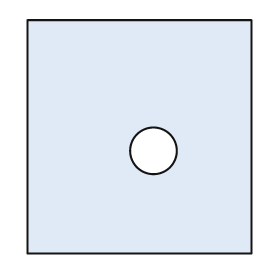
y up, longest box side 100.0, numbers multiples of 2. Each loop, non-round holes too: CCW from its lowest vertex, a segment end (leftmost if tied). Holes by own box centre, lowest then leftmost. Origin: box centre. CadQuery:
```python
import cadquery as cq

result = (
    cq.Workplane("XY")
    .moveTo(-48.0, -50.0)
    .lineTo(48.0, -50.0)
    .lineTo(48.0, 50.0)
    .lineTo(-48.0, 50.0)
    .close()
    .moveTo(6.0, -6.0)
    .circle(10.0)
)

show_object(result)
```